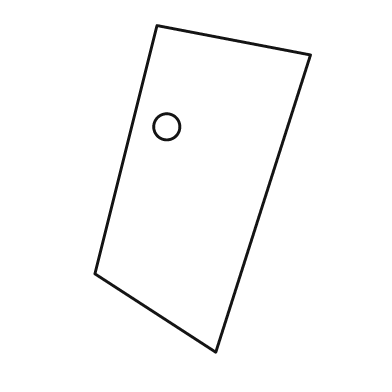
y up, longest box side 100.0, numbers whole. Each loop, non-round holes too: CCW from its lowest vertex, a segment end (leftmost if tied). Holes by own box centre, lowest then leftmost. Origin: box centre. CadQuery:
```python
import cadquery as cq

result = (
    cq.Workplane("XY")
    .moveTo(4.0, -50.0)
    .lineTo(33.0, 41.0)
    .lineTo(-14.0, 50.0)
    .lineTo(-33.0, -26.0)
    .close()
    .moveTo(-11.0, 19.0)
    .circle(4.0)
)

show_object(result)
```